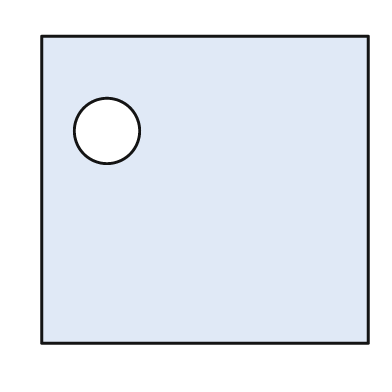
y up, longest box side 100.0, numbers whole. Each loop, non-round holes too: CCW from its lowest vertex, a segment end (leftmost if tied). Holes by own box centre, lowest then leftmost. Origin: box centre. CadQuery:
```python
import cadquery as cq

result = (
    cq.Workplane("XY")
    .moveTo(-50.0, -47.0)
    .lineTo(50.0, -47.0)
    .lineTo(50.0, 47.0)
    .lineTo(-50.0, 47.0)
    .close()
    .moveTo(-30.0, 18.0)
    .circle(10.0)
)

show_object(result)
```